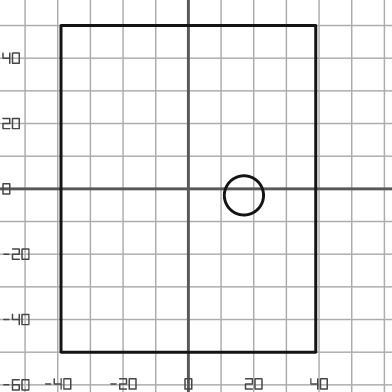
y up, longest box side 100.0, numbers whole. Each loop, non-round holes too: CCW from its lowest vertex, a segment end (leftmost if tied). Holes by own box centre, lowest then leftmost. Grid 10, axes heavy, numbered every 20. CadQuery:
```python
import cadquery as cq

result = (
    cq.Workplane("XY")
    .moveTo(-39.0, -50.0)
    .lineTo(39.0, -50.0)
    .lineTo(39.0, 50.0)
    .lineTo(-39.0, 50.0)
    .close()
    .moveTo(17.0, -2.0)
    .circle(6.0)
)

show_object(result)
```